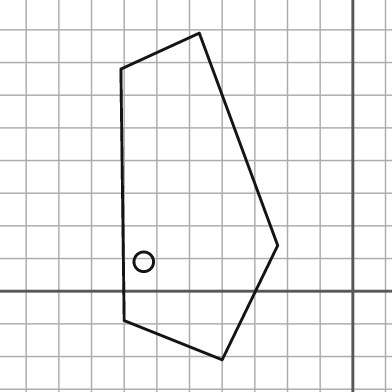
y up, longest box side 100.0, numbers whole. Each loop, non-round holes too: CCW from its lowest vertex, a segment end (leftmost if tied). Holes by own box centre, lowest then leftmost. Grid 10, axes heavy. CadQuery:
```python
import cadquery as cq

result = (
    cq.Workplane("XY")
    .moveTo(-40.0, -21.0)
    .lineTo(-23.0, 14.0)
    .lineTo(-47.0, 79.0)
    .lineTo(-71.0, 68.0)
    .lineTo(-70.0, -9.0)
    .close()
    .moveTo(-64.0, 9.0)
    .circle(3.0)
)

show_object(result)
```